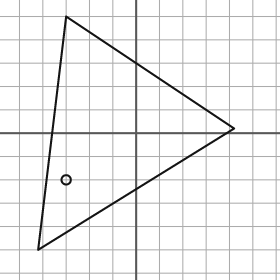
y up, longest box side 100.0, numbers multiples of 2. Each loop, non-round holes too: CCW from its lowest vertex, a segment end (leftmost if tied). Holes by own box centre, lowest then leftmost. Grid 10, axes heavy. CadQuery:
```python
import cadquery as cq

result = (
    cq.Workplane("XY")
    .moveTo(-42.0, -50.0)
    .lineTo(42.0, 2.0)
    .lineTo(-30.0, 50.0)
    .close()
    .moveTo(-30.0, -20.0)
    .circle(2.0)
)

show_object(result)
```